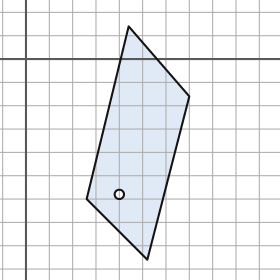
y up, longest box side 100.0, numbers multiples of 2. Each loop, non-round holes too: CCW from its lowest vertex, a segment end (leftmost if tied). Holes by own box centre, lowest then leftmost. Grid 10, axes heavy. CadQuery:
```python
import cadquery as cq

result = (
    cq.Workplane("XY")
    .moveTo(52.0, -86.0)
    .lineTo(70.0, -16.0)
    .lineTo(44.0, 14.0)
    .lineTo(26.0, -60.0)
    .close()
    .moveTo(40.0, -58.0)
    .circle(2.0)
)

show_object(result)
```